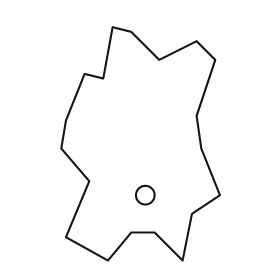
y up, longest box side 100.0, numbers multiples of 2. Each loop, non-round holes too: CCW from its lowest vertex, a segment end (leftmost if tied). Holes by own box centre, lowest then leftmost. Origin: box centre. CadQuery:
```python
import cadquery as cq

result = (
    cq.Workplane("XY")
    .moveTo(-14.0, -50.0)
    .lineTo(-4.0, -38.0)
    .lineTo(6.0, -38.0)
    .lineTo(18.0, -50.0)
    .lineTo(22.0, -30.0)
    .lineTo(34.0, -22.0)
    .lineTo(26.0, -2.0)
    .lineTo(24.0, 12.0)
    .lineTo(32.0, 36.0)
    .lineTo(24.0, 44.0)
    .lineTo(8.0, 36.0)
    .lineTo(-4.0, 48.0)
    .lineTo(-12.0, 50.0)
    .lineTo(-16.0, 28.0)
    .lineTo(-24.0, 30.0)
    .lineTo(-32.0, 10.0)
    .lineTo(-34.0, -2.0)
    .lineTo(-22.0, -16.0)
    .lineTo(-32.0, -40.0)
    .close()
    .moveTo(2.0, -22.0)
    .circle(4.0)
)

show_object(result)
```